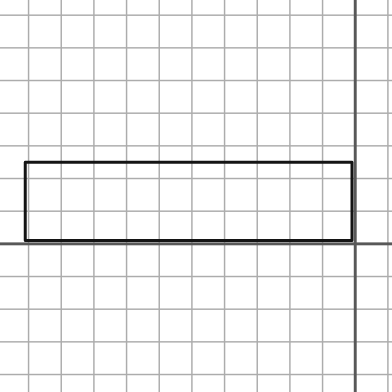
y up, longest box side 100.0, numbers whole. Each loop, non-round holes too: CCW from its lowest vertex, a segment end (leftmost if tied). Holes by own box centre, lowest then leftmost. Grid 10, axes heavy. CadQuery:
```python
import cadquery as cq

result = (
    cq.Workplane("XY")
    .moveTo(-101.0, 1.0)
    .lineTo(-1.0, 1.0)
    .lineTo(-1.0, 25.0)
    .lineTo(-101.0, 25.0)
    .close()
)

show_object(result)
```